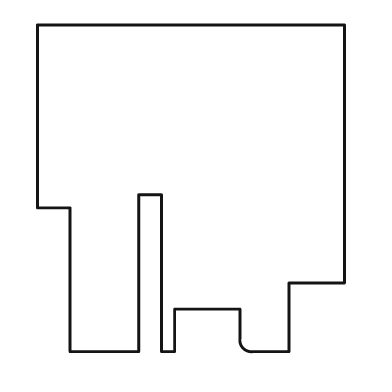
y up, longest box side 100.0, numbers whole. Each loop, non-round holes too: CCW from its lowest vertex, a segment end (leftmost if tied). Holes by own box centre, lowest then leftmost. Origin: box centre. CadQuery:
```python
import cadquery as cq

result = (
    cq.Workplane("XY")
    .moveTo(-37.0, -50.0)
    .lineTo(-16.0, -50.0)
    .lineTo(-16.0, -2.0)
    .lineTo(-9.0, -2.0)
    .lineTo(-9.0, -50.0)
    .lineTo(-5.0, -50.0)
    .lineTo(-5.0, -37.0)
    .lineTo(15.0, -37.0)
    .lineTo(15.0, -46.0)
    .threePointArc((16.0, -49.0), (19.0, -50.0))
    .lineTo(30.0, -50.0)
    .lineTo(30.0, -29.0)
    .lineTo(47.0, -29.0)
    .lineTo(47.0, 50.0)
    .lineTo(-47.0, 50.0)
    .lineTo(-47.0, -6.0)
    .lineTo(-37.0, -6.0)
    .close()
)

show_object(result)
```